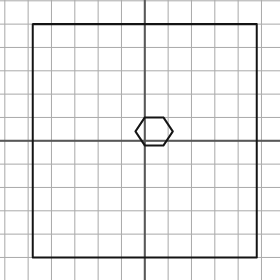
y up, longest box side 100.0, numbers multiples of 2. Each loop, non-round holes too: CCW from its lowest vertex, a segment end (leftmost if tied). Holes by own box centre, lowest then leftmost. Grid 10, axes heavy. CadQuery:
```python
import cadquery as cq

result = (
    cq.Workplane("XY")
    .moveTo(-48.0, -50.0)
    .lineTo(48.0, -50.0)
    .lineTo(48.0, 50.0)
    .lineTo(-48.0, 50.0)
    .close()
    .moveTo(0.0, -2.0)
    .lineTo(8.0, -2.0)
    .lineTo(12.0, 4.0)
    .lineTo(8.0, 10.0)
    .lineTo(0.0, 10.0)
    .lineTo(-4.0, 4.0)
    .close()
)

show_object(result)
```